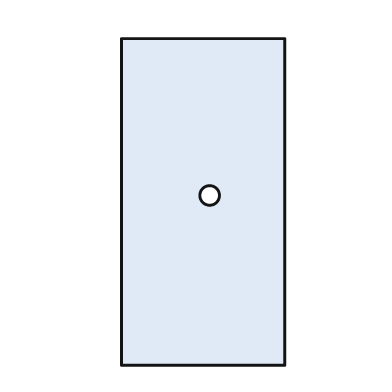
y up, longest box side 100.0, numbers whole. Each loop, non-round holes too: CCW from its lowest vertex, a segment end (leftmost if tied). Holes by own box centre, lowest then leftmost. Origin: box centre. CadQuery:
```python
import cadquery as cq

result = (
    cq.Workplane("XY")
    .moveTo(-25.0, -50.0)
    .lineTo(25.0, -50.0)
    .lineTo(25.0, 50.0)
    .lineTo(-25.0, 50.0)
    .close()
    .moveTo(2.0, 2.0)
    .circle(3.0)
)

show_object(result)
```